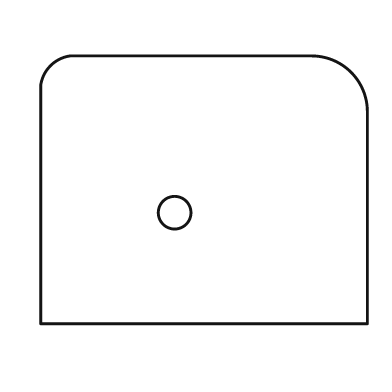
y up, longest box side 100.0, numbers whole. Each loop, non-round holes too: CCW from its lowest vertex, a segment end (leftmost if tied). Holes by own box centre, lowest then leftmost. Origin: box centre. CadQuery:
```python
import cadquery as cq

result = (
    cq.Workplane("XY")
    .moveTo(-50.0, -41.0)
    .lineTo(50.0, -41.0)
    .lineTo(50.0, 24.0)
    .threePointArc((45.0, 36.0), (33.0, 41.0))
    .lineTo(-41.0, 41.0)
    .threePointArc((-47.0, 38.0), (-50.0, 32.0))
    .close()
    .moveTo(-9.0, -7.0)
    .circle(5.0)
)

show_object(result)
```